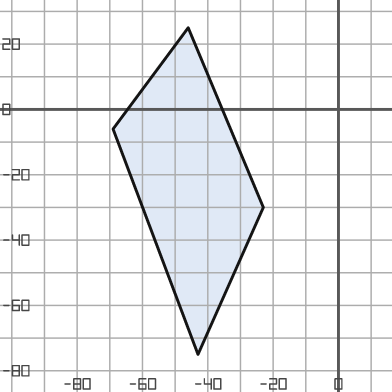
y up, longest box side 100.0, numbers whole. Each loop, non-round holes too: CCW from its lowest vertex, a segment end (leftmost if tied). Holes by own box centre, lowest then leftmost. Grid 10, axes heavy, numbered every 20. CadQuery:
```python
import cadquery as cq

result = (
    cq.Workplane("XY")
    .moveTo(-43.0, -75.0)
    .lineTo(-23.0, -30.0)
    .lineTo(-46.0, 25.0)
    .lineTo(-69.0, -6.0)
    .close()
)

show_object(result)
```